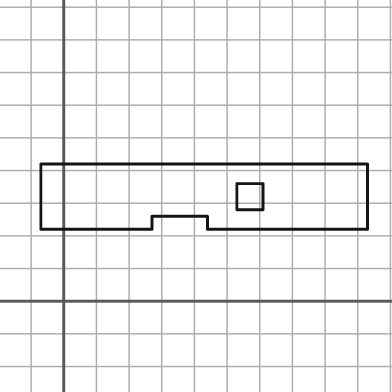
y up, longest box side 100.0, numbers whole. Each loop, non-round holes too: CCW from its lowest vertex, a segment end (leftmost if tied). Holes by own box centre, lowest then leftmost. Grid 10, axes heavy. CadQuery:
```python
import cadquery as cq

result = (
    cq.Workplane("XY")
    .moveTo(-7.0, 22.0)
    .lineTo(27.0, 22.0)
    .lineTo(27.0, 26.0)
    .lineTo(44.0, 26.0)
    .lineTo(44.0, 22.0)
    .lineTo(93.0, 22.0)
    .lineTo(93.0, 42.0)
    .lineTo(-7.0, 42.0)
    .close()
    .moveTo(53.0, 28.0)
    .lineTo(61.0, 28.0)
    .lineTo(61.0, 36.0)
    .lineTo(53.0, 36.0)
    .close()
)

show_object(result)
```